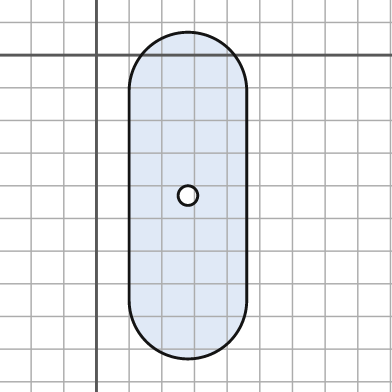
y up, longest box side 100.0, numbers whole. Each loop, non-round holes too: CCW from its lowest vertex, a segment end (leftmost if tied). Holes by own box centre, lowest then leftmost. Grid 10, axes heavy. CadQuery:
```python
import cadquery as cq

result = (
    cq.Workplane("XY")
    .moveTo(10.0, -75.0)
    .threePointArc((28.0, -93.0), (46.0, -75.0))
    .lineTo(46.0, -11.0)
    .threePointArc((28.0, 7.0), (10.0, -11.0))
    .close()
    .moveTo(28.0, -43.0)
    .circle(3.0)
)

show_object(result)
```